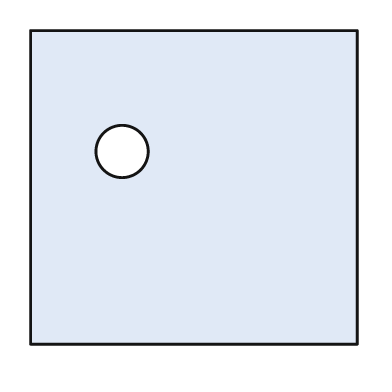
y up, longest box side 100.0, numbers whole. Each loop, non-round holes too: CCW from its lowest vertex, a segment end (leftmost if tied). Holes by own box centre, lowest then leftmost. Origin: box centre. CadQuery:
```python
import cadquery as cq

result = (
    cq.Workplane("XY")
    .moveTo(-50.0, -48.0)
    .lineTo(50.0, -48.0)
    .lineTo(50.0, 48.0)
    .lineTo(-50.0, 48.0)
    .close()
    .moveTo(-22.0, 11.0)
    .circle(8.0)
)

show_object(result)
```